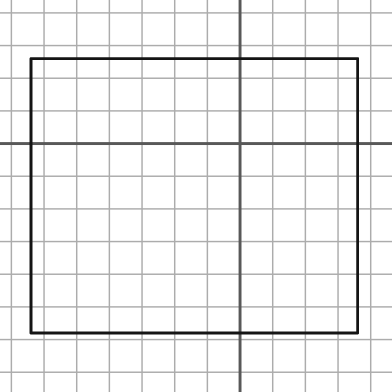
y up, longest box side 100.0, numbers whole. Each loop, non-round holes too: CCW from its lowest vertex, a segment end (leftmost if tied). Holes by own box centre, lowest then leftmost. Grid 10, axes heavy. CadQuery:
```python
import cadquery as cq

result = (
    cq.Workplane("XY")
    .moveTo(-64.0, -58.0)
    .lineTo(36.0, -58.0)
    .lineTo(36.0, 26.0)
    .lineTo(-64.0, 26.0)
    .close()
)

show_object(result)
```